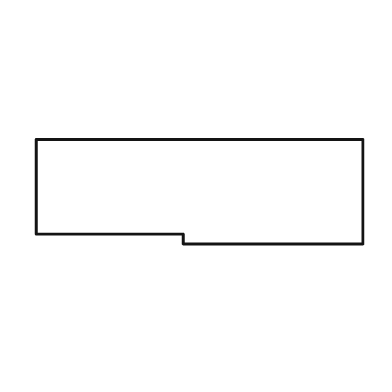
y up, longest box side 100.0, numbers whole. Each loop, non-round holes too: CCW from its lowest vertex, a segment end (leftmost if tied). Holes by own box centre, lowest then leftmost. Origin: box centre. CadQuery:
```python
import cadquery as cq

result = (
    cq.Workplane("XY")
    .moveTo(-5.0, -16.0)
    .lineTo(50.0, -16.0)
    .lineTo(50.0, 16.0)
    .lineTo(-50.0, 16.0)
    .lineTo(-50.0, -13.0)
    .lineTo(-5.0, -13.0)
    .close()
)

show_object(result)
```